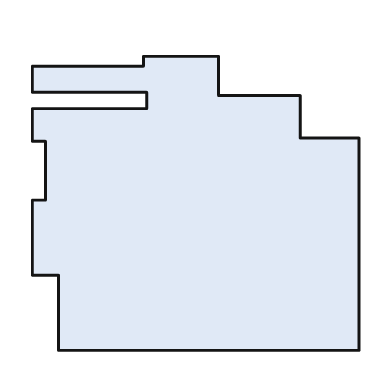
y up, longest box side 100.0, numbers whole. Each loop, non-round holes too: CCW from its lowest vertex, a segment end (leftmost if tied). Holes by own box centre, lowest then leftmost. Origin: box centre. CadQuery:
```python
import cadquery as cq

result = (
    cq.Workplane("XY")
    .moveTo(-42.0, -45.0)
    .lineTo(50.0, -45.0)
    .lineTo(50.0, 20.0)
    .lineTo(32.0, 20.0)
    .lineTo(32.0, 33.0)
    .lineTo(7.0, 33.0)
    .lineTo(7.0, 45.0)
    .lineTo(-16.0, 45.0)
    .lineTo(-16.0, 42.0)
    .lineTo(-50.0, 42.0)
    .lineTo(-50.0, 34.0)
    .lineTo(-15.0, 34.0)
    .lineTo(-15.0, 29.0)
    .lineTo(-50.0, 29.0)
    .lineTo(-50.0, 19.0)
    .lineTo(-46.0, 19.0)
    .lineTo(-46.0, 1.0)
    .lineTo(-50.0, 1.0)
    .lineTo(-50.0, -22.0)
    .lineTo(-42.0, -22.0)
    .close()
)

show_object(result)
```